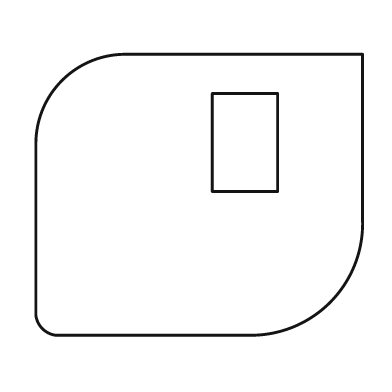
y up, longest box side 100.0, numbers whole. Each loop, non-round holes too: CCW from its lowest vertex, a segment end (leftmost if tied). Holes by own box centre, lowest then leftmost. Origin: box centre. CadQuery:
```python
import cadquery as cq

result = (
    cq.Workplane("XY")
    .moveTo(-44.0, -43.0)
    .lineTo(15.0, -43.0)
    .threePointArc((40.0, -33.0), (50.0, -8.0))
    .lineTo(50.0, 43.0)
    .lineTo(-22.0, 43.0)
    .threePointArc((-42.0, 35.0), (-50.0, 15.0))
    .lineTo(-50.0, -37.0)
    .threePointArc((-48.0, -41.0), (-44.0, -43.0))
    .close()
    .moveTo(4.0, 1.0)
    .lineTo(24.0, 1.0)
    .lineTo(24.0, 31.0)
    .lineTo(4.0, 31.0)
    .close()
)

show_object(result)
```